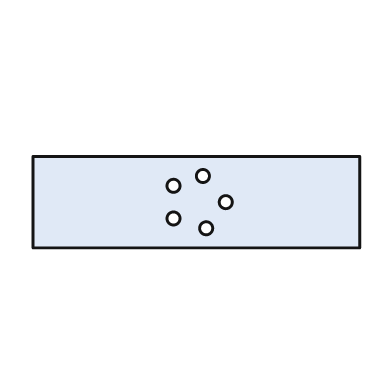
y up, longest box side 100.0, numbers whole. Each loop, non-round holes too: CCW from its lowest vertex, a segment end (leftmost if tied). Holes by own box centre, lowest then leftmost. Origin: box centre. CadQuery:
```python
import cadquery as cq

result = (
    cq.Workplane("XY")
    .moveTo(-50.0, -14.0)
    .lineTo(50.0, -14.0)
    .lineTo(50.0, 14.0)
    .lineTo(-50.0, 14.0)
    .close()
    .moveTo(3.0, -8.0)
    .circle(2.0)
    .moveTo(-7.0, -5.0)
    .circle(2.0)
    .moveTo(9.0, 0.0)
    .circle(2.0)
    .moveTo(-7.0, 5.0)
    .circle(2.0)
    .moveTo(2.0, 8.0)
    .circle(2.0)
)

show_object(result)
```